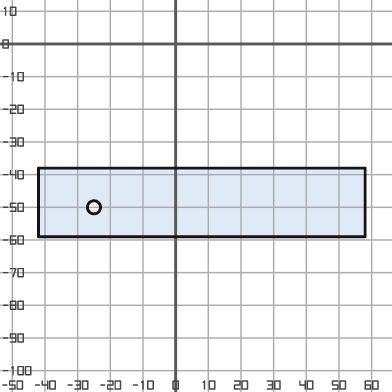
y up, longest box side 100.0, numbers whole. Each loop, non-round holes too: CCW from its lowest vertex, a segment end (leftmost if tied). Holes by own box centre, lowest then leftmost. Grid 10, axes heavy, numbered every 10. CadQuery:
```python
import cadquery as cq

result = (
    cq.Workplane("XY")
    .moveTo(-42.0, -59.0)
    .lineTo(58.0, -59.0)
    .lineTo(58.0, -38.0)
    .lineTo(-42.0, -38.0)
    .close()
    .moveTo(-25.0, -50.0)
    .circle(2.0)
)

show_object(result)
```